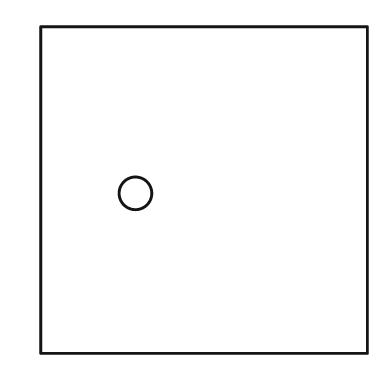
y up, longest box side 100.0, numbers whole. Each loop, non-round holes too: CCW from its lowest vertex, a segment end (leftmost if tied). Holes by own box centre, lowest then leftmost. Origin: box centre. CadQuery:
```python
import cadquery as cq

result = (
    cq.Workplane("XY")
    .moveTo(-50.0, -50.0)
    .lineTo(50.0, -50.0)
    .lineTo(50.0, 50.0)
    .lineTo(-50.0, 50.0)
    .close()
    .moveTo(-21.0, -1.0)
    .circle(5.0)
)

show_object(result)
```